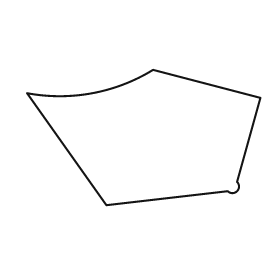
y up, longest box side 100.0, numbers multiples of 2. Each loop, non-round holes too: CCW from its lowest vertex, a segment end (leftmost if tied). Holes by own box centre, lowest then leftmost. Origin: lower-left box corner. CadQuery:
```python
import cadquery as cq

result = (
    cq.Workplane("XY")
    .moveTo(34.0, 0.0)
    .lineTo(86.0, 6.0)
    .threePointArc((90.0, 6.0), (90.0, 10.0))
    .lineTo(100.0, 46.0)
    .lineTo(54.0, 58.0)
    .threePointArc((28.0, 48.0), (0.0, 48.0))
    .close()
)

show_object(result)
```